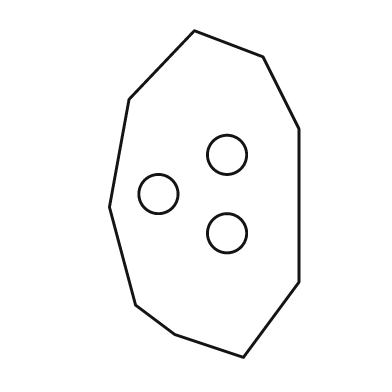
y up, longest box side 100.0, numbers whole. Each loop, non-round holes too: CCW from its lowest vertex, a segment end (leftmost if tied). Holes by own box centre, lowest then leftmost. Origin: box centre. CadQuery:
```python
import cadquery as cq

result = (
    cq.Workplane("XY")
    .moveTo(12.0, -50.0)
    .lineTo(29.0, -27.0)
    .lineTo(29.0, 20.0)
    .lineTo(18.0, 42.0)
    .lineTo(-3.0, 50.0)
    .lineTo(-23.0, 29.0)
    .lineTo(-29.0, -4.0)
    .lineTo(-21.0, -34.0)
    .lineTo(-9.0, -43.0)
    .close()
    .moveTo(7.0, -12.0)
    .circle(6.0)
    .moveTo(-14.0, 0.0)
    .circle(6.0)
    .moveTo(7.0, 12.0)
    .circle(6.0)
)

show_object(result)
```